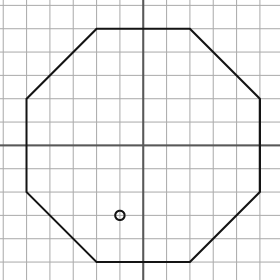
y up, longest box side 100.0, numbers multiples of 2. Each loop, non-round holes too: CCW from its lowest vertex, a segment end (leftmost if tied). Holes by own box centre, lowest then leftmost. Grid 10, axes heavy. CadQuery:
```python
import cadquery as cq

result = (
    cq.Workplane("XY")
    .moveTo(-20.0, -50.0)
    .lineTo(20.0, -50.0)
    .lineTo(50.0, -20.0)
    .lineTo(50.0, 20.0)
    .lineTo(20.0, 50.0)
    .lineTo(-20.0, 50.0)
    .lineTo(-50.0, 20.0)
    .lineTo(-50.0, -20.0)
    .close()
    .moveTo(-10.0, -30.0)
    .circle(2.0)
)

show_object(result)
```